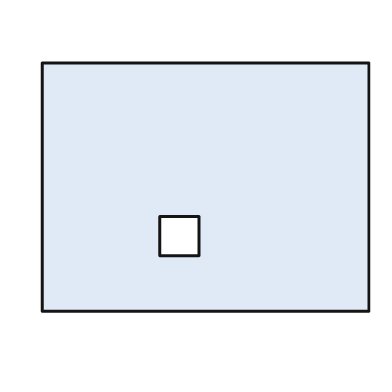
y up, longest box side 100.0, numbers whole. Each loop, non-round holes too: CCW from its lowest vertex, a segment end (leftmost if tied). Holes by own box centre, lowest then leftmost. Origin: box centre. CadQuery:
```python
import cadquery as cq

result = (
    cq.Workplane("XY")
    .moveTo(-50.0, -38.0)
    .lineTo(50.0, -38.0)
    .lineTo(50.0, 38.0)
    .lineTo(-50.0, 38.0)
    .close()
    .moveTo(-14.0, -21.0)
    .lineTo(-2.0, -21.0)
    .lineTo(-2.0, -9.0)
    .lineTo(-14.0, -9.0)
    .close()
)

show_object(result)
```